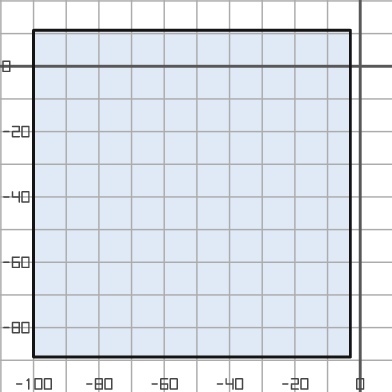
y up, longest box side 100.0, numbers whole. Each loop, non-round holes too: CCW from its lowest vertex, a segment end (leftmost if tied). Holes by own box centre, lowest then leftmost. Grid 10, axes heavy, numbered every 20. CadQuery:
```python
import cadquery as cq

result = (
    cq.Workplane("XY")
    .moveTo(-100.0, -89.0)
    .lineTo(-3.0, -89.0)
    .lineTo(-3.0, 11.0)
    .lineTo(-100.0, 11.0)
    .close()
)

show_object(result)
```